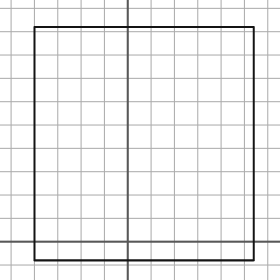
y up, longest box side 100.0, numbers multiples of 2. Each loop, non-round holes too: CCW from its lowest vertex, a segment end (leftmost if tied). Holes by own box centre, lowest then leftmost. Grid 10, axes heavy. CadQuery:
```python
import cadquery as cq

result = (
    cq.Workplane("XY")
    .moveTo(-40.0, -8.0)
    .lineTo(54.0, -8.0)
    .lineTo(54.0, 92.0)
    .lineTo(-40.0, 92.0)
    .close()
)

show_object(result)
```